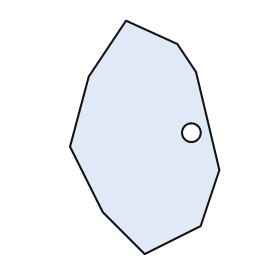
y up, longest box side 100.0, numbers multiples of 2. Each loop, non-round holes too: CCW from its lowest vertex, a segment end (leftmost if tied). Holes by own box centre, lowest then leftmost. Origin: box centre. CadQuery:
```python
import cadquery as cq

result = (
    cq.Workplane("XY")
    .moveTo(0.0, -50.0)
    .lineTo(24.0, -38.0)
    .lineTo(32.0, -14.0)
    .lineTo(22.0, 28.0)
    .lineTo(14.0, 40.0)
    .lineTo(-8.0, 50.0)
    .lineTo(-24.0, 26.0)
    .lineTo(-32.0, -4.0)
    .lineTo(-18.0, -32.0)
    .close()
    .moveTo(20.0, 2.0)
    .circle(4.0)
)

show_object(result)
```